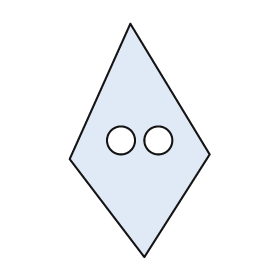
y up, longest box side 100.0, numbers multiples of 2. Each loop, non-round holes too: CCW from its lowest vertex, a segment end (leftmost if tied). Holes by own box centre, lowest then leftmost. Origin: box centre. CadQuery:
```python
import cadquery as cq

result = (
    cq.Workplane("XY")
    .moveTo(2.0, -50.0)
    .lineTo(30.0, -6.0)
    .lineTo(-4.0, 50.0)
    .lineTo(-30.0, -8.0)
    .close()
    .moveTo(-8.0, 0.0)
    .circle(6.0)
    .moveTo(8.0, 0.0)
    .circle(6.0)
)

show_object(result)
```